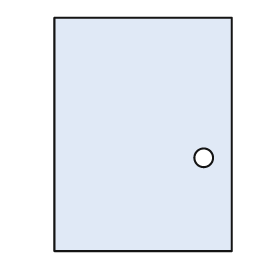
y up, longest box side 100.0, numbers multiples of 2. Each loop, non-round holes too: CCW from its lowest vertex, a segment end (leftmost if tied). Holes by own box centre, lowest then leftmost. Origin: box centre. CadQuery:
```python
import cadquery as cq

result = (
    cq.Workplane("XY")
    .moveTo(-38.0, -50.0)
    .lineTo(38.0, -50.0)
    .lineTo(38.0, 50.0)
    .lineTo(-38.0, 50.0)
    .close()
    .moveTo(26.0, -10.0)
    .circle(4.0)
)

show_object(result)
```